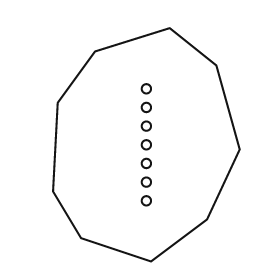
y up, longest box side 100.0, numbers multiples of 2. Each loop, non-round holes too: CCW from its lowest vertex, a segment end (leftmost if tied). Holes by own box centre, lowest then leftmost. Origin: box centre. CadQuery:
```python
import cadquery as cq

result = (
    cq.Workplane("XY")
    .moveTo(2.0, -50.0)
    .lineTo(26.0, -32.0)
    .lineTo(40.0, -2.0)
    .lineTo(30.0, 34.0)
    .lineTo(10.0, 50.0)
    .lineTo(-22.0, 40.0)
    .lineTo(-38.0, 18.0)
    .lineTo(-40.0, -20.0)
    .lineTo(-28.0, -40.0)
    .close()
    .moveTo(0.0, -24.0)
    .circle(2.0)
    .moveTo(0.0, -16.0)
    .circle(2.0)
    .moveTo(0.0, -8.0)
    .circle(2.0)
    .moveTo(0.0, 0.0)
    .circle(2.0)
    .moveTo(0.0, 8.0)
    .circle(2.0)
    .moveTo(0.0, 16.0)
    .circle(2.0)
    .moveTo(0.0, 24.0)
    .circle(2.0)
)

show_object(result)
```